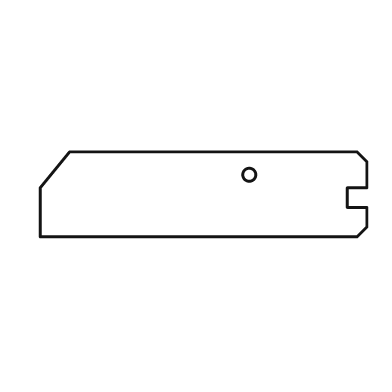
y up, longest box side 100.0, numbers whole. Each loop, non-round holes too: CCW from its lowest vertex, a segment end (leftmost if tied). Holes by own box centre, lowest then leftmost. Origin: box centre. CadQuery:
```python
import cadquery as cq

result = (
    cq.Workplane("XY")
    .moveTo(-50.0, -13.0)
    .lineTo(47.0, -13.0)
    .lineTo(50.0, -10.0)
    .lineTo(50.0, -4.0)
    .lineTo(44.0, -4.0)
    .lineTo(44.0, 2.0)
    .lineTo(50.0, 2.0)
    .lineTo(50.0, 10.0)
    .lineTo(47.0, 13.0)
    .lineTo(-41.0, 13.0)
    .lineTo(-50.0, 2.0)
    .close()
    .moveTo(14.0, 6.0)
    .circle(2.0)
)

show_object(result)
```